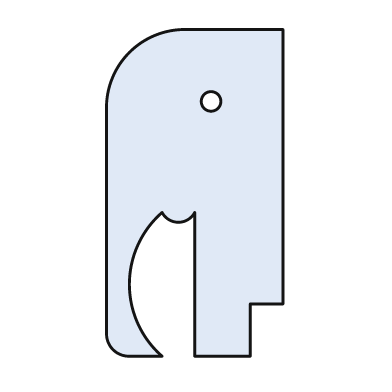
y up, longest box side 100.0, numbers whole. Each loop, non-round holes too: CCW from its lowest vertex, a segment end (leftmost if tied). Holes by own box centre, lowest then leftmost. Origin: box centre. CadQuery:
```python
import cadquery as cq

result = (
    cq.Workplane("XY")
    .moveTo(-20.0, -50.0)
    .lineTo(-10.0, -50.0)
    .threePointArc((-20.0, -28.0), (-10.0, -6.0))
    .threePointArc((-5.0, -9.0), (0.0, -6.0))
    .lineTo(0.0, -50.0)
    .lineTo(17.0, -50.0)
    .lineTo(17.0, -34.0)
    .lineTo(27.0, -34.0)
    .lineTo(27.0, 50.0)
    .lineTo(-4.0, 50.0)
    .threePointArc((-20.0, 43.0), (-27.0, 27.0))
    .lineTo(-27.0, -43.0)
    .threePointArc((-25.0, -48.0), (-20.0, -50.0))
    .close()
    .moveTo(5.0, 28.0)
    .circle(3.0)
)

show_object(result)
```